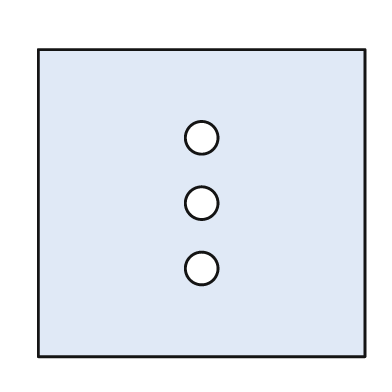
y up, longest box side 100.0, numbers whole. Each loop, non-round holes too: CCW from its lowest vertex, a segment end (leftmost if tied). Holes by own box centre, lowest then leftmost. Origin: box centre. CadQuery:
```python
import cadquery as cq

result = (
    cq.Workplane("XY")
    .moveTo(-50.0, -47.0)
    .lineTo(50.0, -47.0)
    .lineTo(50.0, 47.0)
    .lineTo(-50.0, 47.0)
    .close()
    .moveTo(0.0, -20.0)
    .circle(5.0)
    .moveTo(0.0, 0.0)
    .circle(5.0)
    .moveTo(0.0, 20.0)
    .circle(5.0)
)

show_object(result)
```